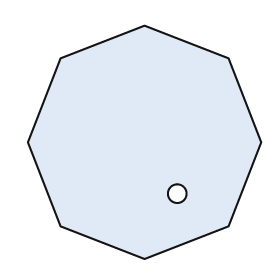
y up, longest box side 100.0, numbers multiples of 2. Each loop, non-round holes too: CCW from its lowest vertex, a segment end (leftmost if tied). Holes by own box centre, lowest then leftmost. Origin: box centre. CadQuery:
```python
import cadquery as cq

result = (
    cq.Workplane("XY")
    .moveTo(0.0, -50.0)
    .lineTo(36.0, -36.0)
    .lineTo(50.0, 0.0)
    .lineTo(36.0, 36.0)
    .lineTo(0.0, 50.0)
    .lineTo(-36.0, 36.0)
    .lineTo(-50.0, 0.0)
    .lineTo(-36.0, -36.0)
    .close()
    .moveTo(14.0, -22.0)
    .circle(4.0)
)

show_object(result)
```